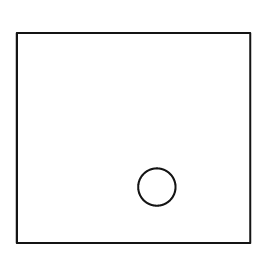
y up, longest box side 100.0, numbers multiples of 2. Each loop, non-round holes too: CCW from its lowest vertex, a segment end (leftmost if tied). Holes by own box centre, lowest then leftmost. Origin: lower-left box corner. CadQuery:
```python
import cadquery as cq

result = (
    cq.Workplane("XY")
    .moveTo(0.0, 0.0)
    .lineTo(100.0, 0.0)
    .lineTo(100.0, 90.0)
    .lineTo(0.0, 90.0)
    .close()
    .moveTo(60.0, 24.0)
    .circle(8.0)
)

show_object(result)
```